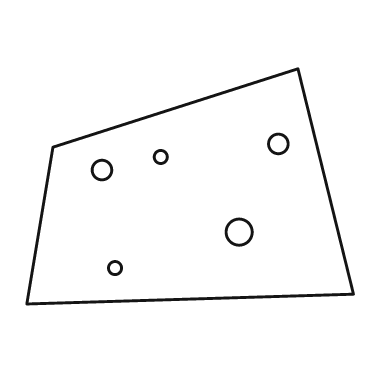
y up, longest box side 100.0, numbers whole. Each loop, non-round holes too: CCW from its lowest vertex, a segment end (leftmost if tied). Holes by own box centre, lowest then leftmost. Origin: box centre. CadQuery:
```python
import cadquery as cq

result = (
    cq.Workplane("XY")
    .moveTo(-50.0, -36.0)
    .lineTo(50.0, -33.0)
    .lineTo(33.0, 36.0)
    .lineTo(-42.0, 12.0)
    .close()
    .moveTo(-23.0, -25.0)
    .circle(2.0)
    .moveTo(15.0, -14.0)
    .circle(4.0)
    .moveTo(-27.0, 5.0)
    .circle(3.0)
    .moveTo(-9.0, 9.0)
    .circle(2.0)
    .moveTo(27.0, 13.0)
    .circle(3.0)
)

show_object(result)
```